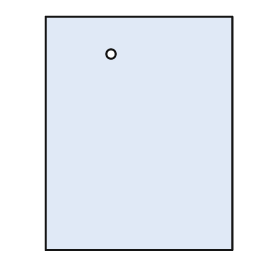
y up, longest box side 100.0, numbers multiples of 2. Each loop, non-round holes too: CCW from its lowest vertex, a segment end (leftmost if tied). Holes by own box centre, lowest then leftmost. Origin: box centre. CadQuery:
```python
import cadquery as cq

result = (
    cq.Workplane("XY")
    .moveTo(-40.0, -50.0)
    .lineTo(40.0, -50.0)
    .lineTo(40.0, 50.0)
    .lineTo(-40.0, 50.0)
    .close()
    .moveTo(-12.0, 34.0)
    .circle(2.0)
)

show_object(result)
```